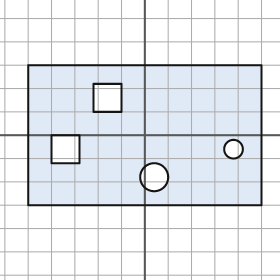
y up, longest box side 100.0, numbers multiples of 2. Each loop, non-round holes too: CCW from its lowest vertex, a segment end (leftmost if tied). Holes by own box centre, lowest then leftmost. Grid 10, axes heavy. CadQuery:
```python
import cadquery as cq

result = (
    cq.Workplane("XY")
    .moveTo(-50.0, -30.0)
    .lineTo(50.0, -30.0)
    .lineTo(50.0, 30.0)
    .lineTo(-50.0, 30.0)
    .close()
    .moveTo(4.0, -18.0)
    .circle(6.0)
    .moveTo(-40.0, -12.0)
    .lineTo(-28.0, -12.0)
    .lineTo(-28.0, 0.0)
    .lineTo(-40.0, 0.0)
    .close()
    .moveTo(38.0, -6.0)
    .circle(4.0)
    .moveTo(-22.0, 10.0)
    .lineTo(-10.0, 10.0)
    .lineTo(-10.0, 22.0)
    .lineTo(-22.0, 22.0)
    .close()
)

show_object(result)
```